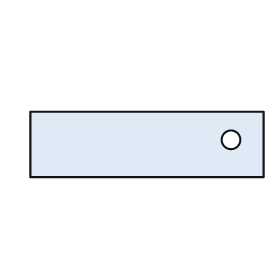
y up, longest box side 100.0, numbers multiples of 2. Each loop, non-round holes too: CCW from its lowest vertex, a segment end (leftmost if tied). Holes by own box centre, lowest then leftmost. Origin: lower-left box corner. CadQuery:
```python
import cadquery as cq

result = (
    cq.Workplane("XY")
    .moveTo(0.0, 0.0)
    .lineTo(100.0, 0.0)
    .lineTo(100.0, 28.0)
    .lineTo(0.0, 28.0)
    .close()
    .moveTo(86.0, 16.0)
    .circle(4.0)
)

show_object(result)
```